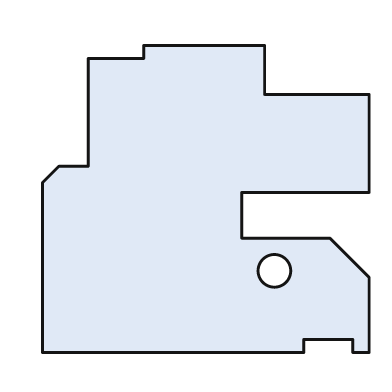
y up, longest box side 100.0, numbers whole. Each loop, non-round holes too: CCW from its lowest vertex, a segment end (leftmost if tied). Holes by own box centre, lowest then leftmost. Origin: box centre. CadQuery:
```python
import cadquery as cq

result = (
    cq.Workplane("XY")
    .moveTo(-50.0, -47.0)
    .lineTo(30.0, -47.0)
    .lineTo(30.0, -43.0)
    .lineTo(45.0, -43.0)
    .lineTo(45.0, -47.0)
    .lineTo(50.0, -47.0)
    .lineTo(50.0, -24.0)
    .lineTo(38.0, -12.0)
    .lineTo(11.0, -12.0)
    .lineTo(11.0, 2.0)
    .lineTo(50.0, 2.0)
    .lineTo(50.0, 32.0)
    .lineTo(18.0, 32.0)
    .lineTo(18.0, 47.0)
    .lineTo(-19.0, 47.0)
    .lineTo(-19.0, 43.0)
    .lineTo(-36.0, 43.0)
    .lineTo(-36.0, 10.0)
    .lineTo(-45.0, 10.0)
    .lineTo(-50.0, 5.0)
    .close()
    .moveTo(21.0, -22.0)
    .circle(5.0)
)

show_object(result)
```